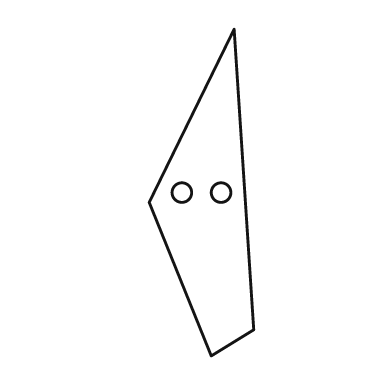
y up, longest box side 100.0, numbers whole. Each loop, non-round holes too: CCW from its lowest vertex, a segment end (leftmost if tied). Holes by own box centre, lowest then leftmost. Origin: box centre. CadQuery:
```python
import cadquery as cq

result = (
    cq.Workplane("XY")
    .moveTo(3.0, -50.0)
    .lineTo(16.0, -42.0)
    .lineTo(10.0, 50.0)
    .lineTo(-16.0, -3.0)
    .close()
    .moveTo(-6.0, 0.0)
    .circle(3.0)
    .moveTo(6.0, 0.0)
    .circle(3.0)
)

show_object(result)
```